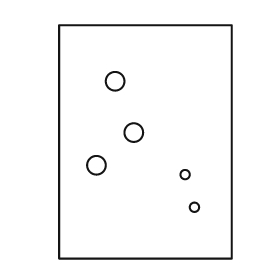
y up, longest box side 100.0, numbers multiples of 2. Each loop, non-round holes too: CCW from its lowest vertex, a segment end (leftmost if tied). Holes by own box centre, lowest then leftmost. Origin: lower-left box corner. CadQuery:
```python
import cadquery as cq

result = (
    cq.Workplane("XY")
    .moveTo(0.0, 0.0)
    .lineTo(74.0, 0.0)
    .lineTo(74.0, 100.0)
    .lineTo(0.0, 100.0)
    .close()
    .moveTo(58.0, 22.0)
    .circle(2.0)
    .moveTo(54.0, 36.0)
    .circle(2.0)
    .moveTo(16.0, 40.0)
    .circle(4.0)
    .moveTo(32.0, 54.0)
    .circle(4.0)
    .moveTo(24.0, 76.0)
    .circle(4.0)
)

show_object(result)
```